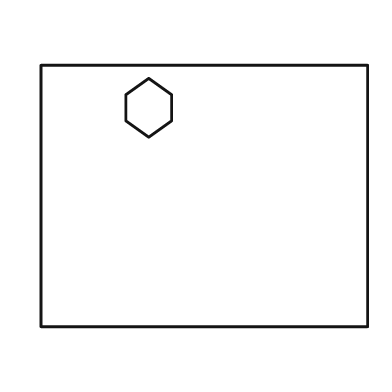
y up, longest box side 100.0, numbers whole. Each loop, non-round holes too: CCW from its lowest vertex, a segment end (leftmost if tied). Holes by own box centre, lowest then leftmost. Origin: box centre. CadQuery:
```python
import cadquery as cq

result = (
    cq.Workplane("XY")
    .moveTo(-50.0, -40.0)
    .lineTo(50.0, -40.0)
    .lineTo(50.0, 40.0)
    .lineTo(-50.0, 40.0)
    .close()
    .moveTo(-17.0, 18.0)
    .lineTo(-10.0, 23.0)
    .lineTo(-10.0, 31.0)
    .lineTo(-17.0, 36.0)
    .lineTo(-24.0, 31.0)
    .lineTo(-24.0, 23.0)
    .close()
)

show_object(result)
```